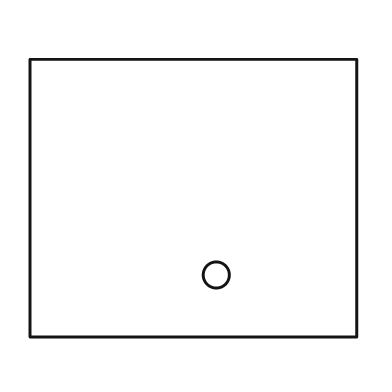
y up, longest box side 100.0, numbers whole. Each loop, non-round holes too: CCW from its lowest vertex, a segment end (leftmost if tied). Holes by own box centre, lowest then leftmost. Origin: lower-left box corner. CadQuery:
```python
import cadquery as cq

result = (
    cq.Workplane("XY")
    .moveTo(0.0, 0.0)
    .lineTo(100.0, 0.0)
    .lineTo(100.0, 85.0)
    .lineTo(0.0, 85.0)
    .close()
    .moveTo(57.0, 19.0)
    .circle(4.0)
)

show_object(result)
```